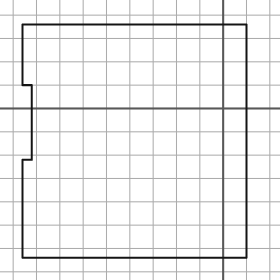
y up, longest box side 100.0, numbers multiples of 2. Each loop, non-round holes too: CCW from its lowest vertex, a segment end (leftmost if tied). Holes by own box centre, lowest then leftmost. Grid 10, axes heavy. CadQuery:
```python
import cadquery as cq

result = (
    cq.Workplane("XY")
    .moveTo(-86.0, -64.0)
    .lineTo(10.0, -64.0)
    .lineTo(10.0, 36.0)
    .lineTo(-86.0, 36.0)
    .lineTo(-86.0, 10.0)
    .lineTo(-82.0, 10.0)
    .lineTo(-82.0, -22.0)
    .lineTo(-86.0, -22.0)
    .close()
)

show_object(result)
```